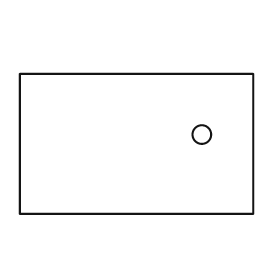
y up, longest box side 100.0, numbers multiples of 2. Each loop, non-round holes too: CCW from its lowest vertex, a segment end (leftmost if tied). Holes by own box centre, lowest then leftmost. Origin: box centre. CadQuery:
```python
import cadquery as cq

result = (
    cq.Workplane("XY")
    .moveTo(-50.0, -30.0)
    .lineTo(50.0, -30.0)
    .lineTo(50.0, 30.0)
    .lineTo(-50.0, 30.0)
    .close()
    .moveTo(28.0, 4.0)
    .circle(4.0)
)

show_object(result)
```